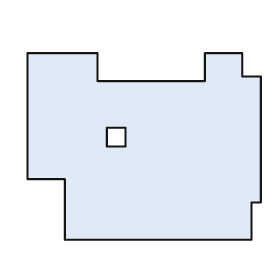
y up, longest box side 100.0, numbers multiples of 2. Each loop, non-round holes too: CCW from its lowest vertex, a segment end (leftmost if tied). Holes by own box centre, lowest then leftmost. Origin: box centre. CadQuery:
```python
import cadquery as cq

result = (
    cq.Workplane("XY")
    .moveTo(-34.0, -40.0)
    .lineTo(46.0, -40.0)
    .lineTo(46.0, -24.0)
    .lineTo(50.0, -24.0)
    .lineTo(50.0, 30.0)
    .lineTo(42.0, 30.0)
    .lineTo(42.0, 40.0)
    .lineTo(26.0, 40.0)
    .lineTo(26.0, 28.0)
    .lineTo(-20.0, 28.0)
    .lineTo(-20.0, 40.0)
    .lineTo(-50.0, 40.0)
    .lineTo(-50.0, -14.0)
    .lineTo(-34.0, -14.0)
    .close()
    .moveTo(-16.0, 0.0)
    .lineTo(-8.0, 0.0)
    .lineTo(-8.0, 8.0)
    .lineTo(-16.0, 8.0)
    .close()
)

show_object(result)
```